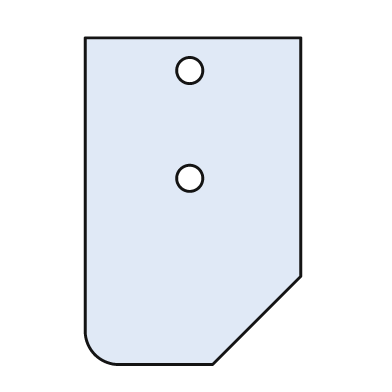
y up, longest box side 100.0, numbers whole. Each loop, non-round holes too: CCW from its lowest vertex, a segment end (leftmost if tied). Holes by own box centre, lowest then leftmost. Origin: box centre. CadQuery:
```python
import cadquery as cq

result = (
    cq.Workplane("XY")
    .moveTo(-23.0, -50.0)
    .lineTo(6.0, -50.0)
    .lineTo(33.0, -23.0)
    .lineTo(33.0, 50.0)
    .lineTo(-33.0, 50.0)
    .lineTo(-33.0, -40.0)
    .threePointArc((-30.0, -47.0), (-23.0, -50.0))
    .close()
    .moveTo(-1.0, 7.0)
    .circle(4.0)
    .moveTo(-1.0, 40.0)
    .circle(4.0)
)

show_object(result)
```